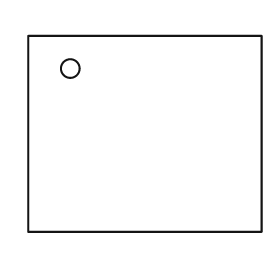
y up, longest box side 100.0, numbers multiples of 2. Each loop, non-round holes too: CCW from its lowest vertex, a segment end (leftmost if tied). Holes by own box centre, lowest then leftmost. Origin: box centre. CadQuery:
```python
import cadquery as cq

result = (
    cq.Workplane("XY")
    .moveTo(-50.0, -42.0)
    .lineTo(50.0, -42.0)
    .lineTo(50.0, 42.0)
    .lineTo(-50.0, 42.0)
    .close()
    .moveTo(-32.0, 28.0)
    .circle(4.0)
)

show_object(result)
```